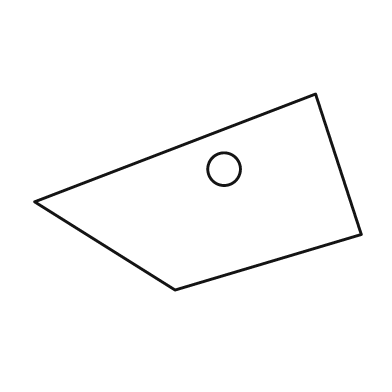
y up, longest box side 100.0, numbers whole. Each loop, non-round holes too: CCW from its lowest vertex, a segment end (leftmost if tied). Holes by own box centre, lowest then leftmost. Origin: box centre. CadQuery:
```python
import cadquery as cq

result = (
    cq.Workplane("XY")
    .moveTo(-7.0, -30.0)
    .lineTo(50.0, -13.0)
    .lineTo(36.0, 30.0)
    .lineTo(-50.0, -3.0)
    .close()
    .moveTo(8.0, 7.0)
    .circle(5.0)
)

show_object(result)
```